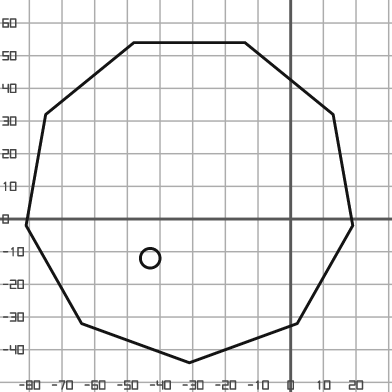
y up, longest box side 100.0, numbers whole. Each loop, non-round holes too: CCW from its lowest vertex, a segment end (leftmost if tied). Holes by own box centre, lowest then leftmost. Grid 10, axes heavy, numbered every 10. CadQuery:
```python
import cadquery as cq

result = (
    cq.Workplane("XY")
    .moveTo(-31.0, -44.0)
    .lineTo(2.0, -32.0)
    .lineTo(19.0, -2.0)
    .lineTo(13.0, 32.0)
    .lineTo(-14.0, 54.0)
    .lineTo(-48.0, 54.0)
    .lineTo(-75.0, 32.0)
    .lineTo(-81.0, -2.0)
    .lineTo(-64.0, -32.0)
    .close()
    .moveTo(-43.0, -12.0)
    .circle(3.0)
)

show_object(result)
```